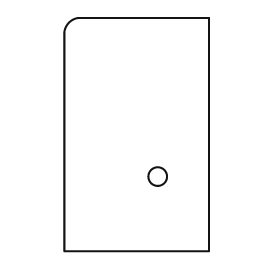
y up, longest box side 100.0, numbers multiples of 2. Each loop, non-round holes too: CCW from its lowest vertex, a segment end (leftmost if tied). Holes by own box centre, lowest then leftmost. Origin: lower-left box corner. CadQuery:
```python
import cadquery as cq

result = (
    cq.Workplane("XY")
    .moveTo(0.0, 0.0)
    .lineTo(62.0, 0.0)
    .lineTo(62.0, 100.0)
    .lineTo(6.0, 100.0)
    .threePointArc((2.0, 98.0), (0.0, 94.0))
    .close()
    .moveTo(40.0, 32.0)
    .circle(4.0)
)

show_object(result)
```